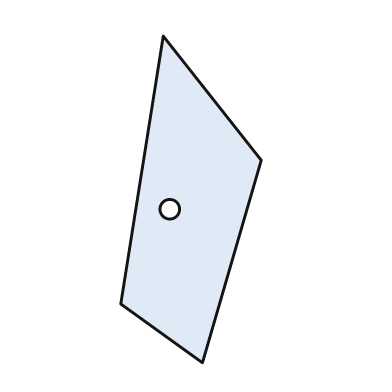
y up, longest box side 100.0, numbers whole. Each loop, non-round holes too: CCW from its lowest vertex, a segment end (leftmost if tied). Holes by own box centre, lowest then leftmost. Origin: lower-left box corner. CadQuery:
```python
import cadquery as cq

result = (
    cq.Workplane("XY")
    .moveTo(25.0, 0.0)
    .lineTo(43.0, 62.0)
    .lineTo(13.0, 100.0)
    .lineTo(0.0, 18.0)
    .close()
    .moveTo(15.0, 47.0)
    .circle(3.0)
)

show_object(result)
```